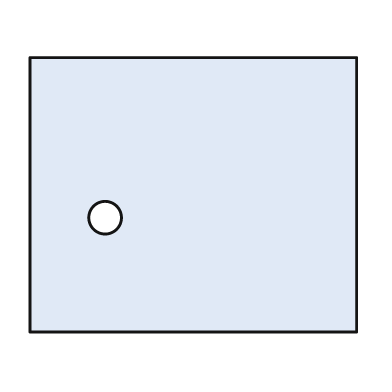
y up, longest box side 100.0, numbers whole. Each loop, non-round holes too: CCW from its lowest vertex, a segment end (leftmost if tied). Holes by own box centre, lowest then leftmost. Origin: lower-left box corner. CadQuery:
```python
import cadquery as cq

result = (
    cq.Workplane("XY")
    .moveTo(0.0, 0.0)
    .lineTo(100.0, 0.0)
    .lineTo(100.0, 84.0)
    .lineTo(0.0, 84.0)
    .close()
    .moveTo(23.0, 35.0)
    .circle(5.0)
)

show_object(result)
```